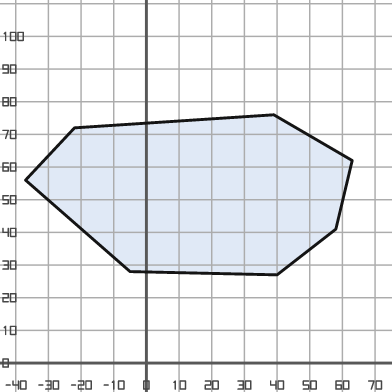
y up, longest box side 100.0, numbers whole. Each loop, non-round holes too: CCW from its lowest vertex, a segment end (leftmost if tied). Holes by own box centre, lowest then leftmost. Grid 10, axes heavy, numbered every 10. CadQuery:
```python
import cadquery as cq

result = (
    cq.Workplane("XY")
    .moveTo(40.0, 27.0)
    .lineTo(58.0, 41.0)
    .lineTo(63.0, 62.0)
    .lineTo(39.0, 76.0)
    .lineTo(-22.0, 72.0)
    .lineTo(-37.0, 56.0)
    .lineTo(-5.0, 28.0)
    .close()
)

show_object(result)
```